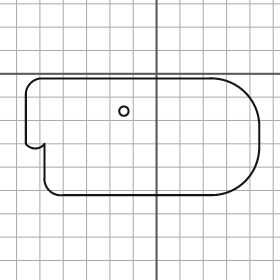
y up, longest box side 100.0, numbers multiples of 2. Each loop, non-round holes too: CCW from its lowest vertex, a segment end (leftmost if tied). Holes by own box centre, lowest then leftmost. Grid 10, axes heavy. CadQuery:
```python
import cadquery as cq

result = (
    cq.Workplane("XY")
    .moveTo(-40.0, -52.0)
    .lineTo(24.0, -52.0)
    .threePointArc((38.0, -46.0), (44.0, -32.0))
    .lineTo(44.0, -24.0)
    .threePointArc((38.0, -8.0), (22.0, -2.0))
    .lineTo(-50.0, -2.0)
    .threePointArc((-54.0, -4.0), (-56.0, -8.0))
    .lineTo(-56.0, -30.0)
    .threePointArc((-52.0, -32.0), (-48.0, -30.0))
    .lineTo(-48.0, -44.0)
    .threePointArc((-46.0, -50.0), (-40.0, -52.0))
    .close()
    .moveTo(-14.0, -16.0)
    .circle(2.0)
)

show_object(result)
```